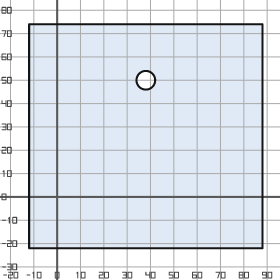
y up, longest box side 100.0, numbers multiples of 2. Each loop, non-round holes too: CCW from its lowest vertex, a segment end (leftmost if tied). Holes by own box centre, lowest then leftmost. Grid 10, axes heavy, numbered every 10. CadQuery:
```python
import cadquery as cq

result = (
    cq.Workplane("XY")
    .moveTo(-12.0, -22.0)
    .lineTo(88.0, -22.0)
    .lineTo(88.0, 74.0)
    .lineTo(-12.0, 74.0)
    .close()
    .moveTo(38.0, 50.0)
    .circle(4.0)
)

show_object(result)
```